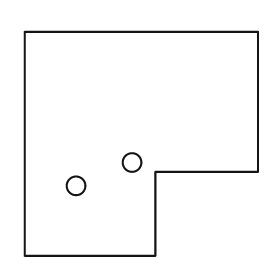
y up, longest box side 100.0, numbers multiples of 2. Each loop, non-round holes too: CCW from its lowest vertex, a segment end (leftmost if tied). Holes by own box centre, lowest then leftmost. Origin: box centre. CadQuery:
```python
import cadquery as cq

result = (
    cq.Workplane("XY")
    .moveTo(-50.0, -48.0)
    .lineTo(6.0, -48.0)
    .lineTo(6.0, -12.0)
    .lineTo(50.0, -12.0)
    .lineTo(50.0, 48.0)
    .lineTo(-50.0, 48.0)
    .close()
    .moveTo(-28.0, -18.0)
    .circle(4.0)
    .moveTo(-4.0, -8.0)
    .circle(4.0)
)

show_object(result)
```